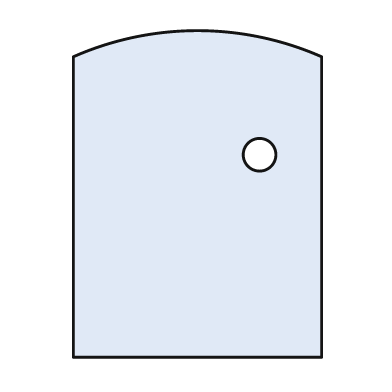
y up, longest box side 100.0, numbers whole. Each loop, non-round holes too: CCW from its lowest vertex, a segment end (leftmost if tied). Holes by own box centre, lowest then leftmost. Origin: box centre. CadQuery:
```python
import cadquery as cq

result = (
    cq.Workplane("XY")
    .moveTo(-38.0, -50.0)
    .lineTo(38.0, -50.0)
    .lineTo(38.0, 42.0)
    .threePointArc((0.0, 50.0), (-38.0, 42.0))
    .close()
    .moveTo(19.0, 12.0)
    .circle(5.0)
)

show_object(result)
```